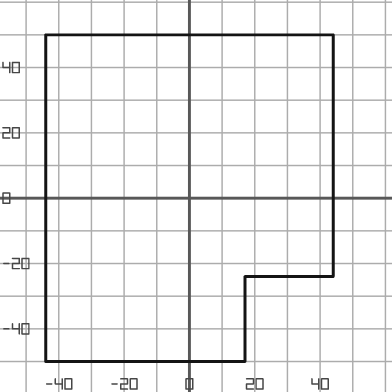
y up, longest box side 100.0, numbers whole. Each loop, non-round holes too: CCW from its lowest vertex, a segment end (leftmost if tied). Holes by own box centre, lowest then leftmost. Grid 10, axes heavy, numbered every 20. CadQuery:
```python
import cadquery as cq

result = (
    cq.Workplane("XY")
    .moveTo(-44.0, -50.0)
    .lineTo(17.0, -50.0)
    .lineTo(17.0, -24.0)
    .lineTo(44.0, -24.0)
    .lineTo(44.0, 50.0)
    .lineTo(-44.0, 50.0)
    .close()
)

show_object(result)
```